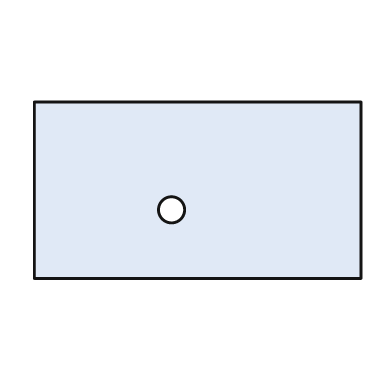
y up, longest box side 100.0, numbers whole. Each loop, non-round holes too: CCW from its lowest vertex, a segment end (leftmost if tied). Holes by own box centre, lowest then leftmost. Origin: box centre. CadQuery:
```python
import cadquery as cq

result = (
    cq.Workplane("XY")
    .moveTo(-50.0, -27.0)
    .lineTo(50.0, -27.0)
    .lineTo(50.0, 27.0)
    .lineTo(-50.0, 27.0)
    .close()
    .moveTo(-8.0, -6.0)
    .circle(4.0)
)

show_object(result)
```